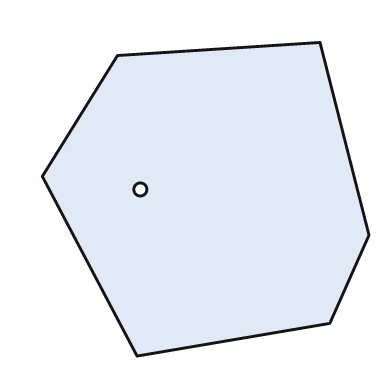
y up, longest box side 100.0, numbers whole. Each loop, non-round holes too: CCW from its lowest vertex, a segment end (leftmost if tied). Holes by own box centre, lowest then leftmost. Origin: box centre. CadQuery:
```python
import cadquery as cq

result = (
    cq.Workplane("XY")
    .moveTo(-21.0, -48.0)
    .lineTo(38.0, -38.0)
    .lineTo(50.0, -11.0)
    .lineTo(35.0, 48.0)
    .lineTo(-27.0, 44.0)
    .lineTo(-50.0, 7.0)
    .close()
    .moveTo(-20.0, 3.0)
    .circle(2.0)
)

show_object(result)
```